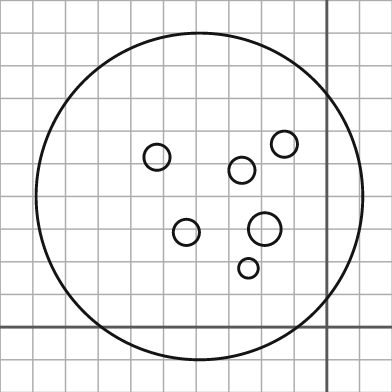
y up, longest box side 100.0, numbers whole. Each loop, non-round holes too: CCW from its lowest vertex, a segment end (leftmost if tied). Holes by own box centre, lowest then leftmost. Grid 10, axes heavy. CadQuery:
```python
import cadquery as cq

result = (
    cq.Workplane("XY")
    .moveTo(-39.0, 40.0)
    .circle(50.0)
    .moveTo(-24.0, 18.0)
    .circle(3.0)
    .moveTo(-43.0, 29.0)
    .circle(4.0)
    .moveTo(-19.0, 30.0)
    .circle(5.0)
    .moveTo(-26.0, 48.0)
    .circle(4.0)
    .moveTo(-52.0, 52.0)
    .circle(4.0)
    .moveTo(-13.0, 56.0)
    .circle(4.0)
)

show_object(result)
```